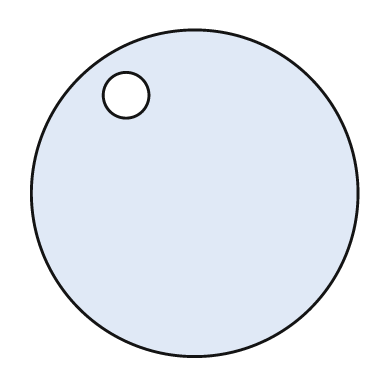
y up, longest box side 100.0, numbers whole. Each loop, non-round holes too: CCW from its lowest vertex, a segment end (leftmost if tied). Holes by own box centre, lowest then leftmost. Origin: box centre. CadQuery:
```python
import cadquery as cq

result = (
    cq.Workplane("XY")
    .moveTo(0.0, 0.0)
    .circle(50.0)
    .moveTo(-21.0, 30.0)
    .circle(7.0)
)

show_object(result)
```